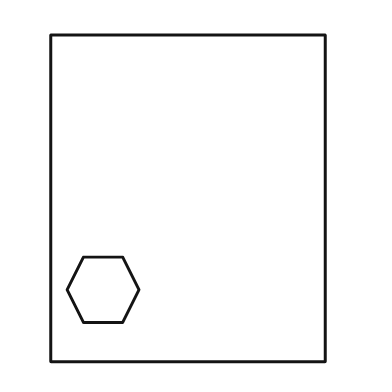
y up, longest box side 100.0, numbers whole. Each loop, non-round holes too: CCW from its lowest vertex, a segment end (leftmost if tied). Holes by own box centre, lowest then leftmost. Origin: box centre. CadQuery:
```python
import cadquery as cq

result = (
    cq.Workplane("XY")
    .moveTo(-42.0, -50.0)
    .lineTo(42.0, -50.0)
    .lineTo(42.0, 50.0)
    .lineTo(-42.0, 50.0)
    .close()
    .moveTo(-32.0, -38.0)
    .lineTo(-20.0, -38.0)
    .lineTo(-15.0, -28.0)
    .lineTo(-20.0, -18.0)
    .lineTo(-32.0, -18.0)
    .lineTo(-37.0, -28.0)
    .close()
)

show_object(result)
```